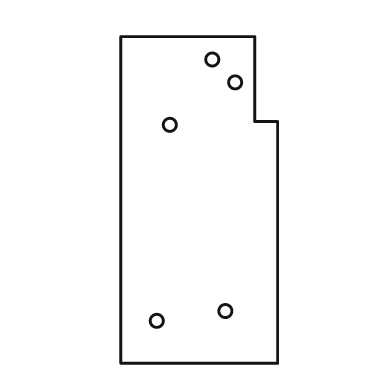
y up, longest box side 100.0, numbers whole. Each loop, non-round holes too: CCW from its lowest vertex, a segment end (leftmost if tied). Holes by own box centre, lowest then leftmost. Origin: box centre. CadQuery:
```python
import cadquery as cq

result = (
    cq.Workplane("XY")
    .moveTo(-24.0, -50.0)
    .lineTo(24.0, -50.0)
    .lineTo(24.0, 24.0)
    .lineTo(17.0, 24.0)
    .lineTo(17.0, 50.0)
    .lineTo(-24.0, 50.0)
    .close()
    .moveTo(-13.0, -37.0)
    .circle(2.0)
    .moveTo(8.0, -34.0)
    .circle(2.0)
    .moveTo(-9.0, 23.0)
    .circle(2.0)
    .moveTo(11.0, 36.0)
    .circle(2.0)
    .moveTo(4.0, 43.0)
    .circle(2.0)
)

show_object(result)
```